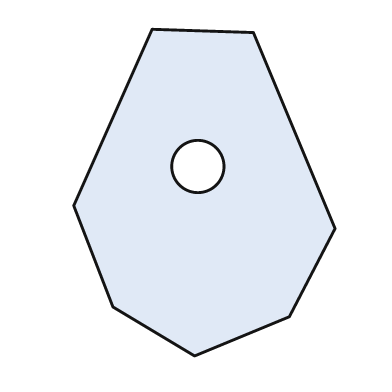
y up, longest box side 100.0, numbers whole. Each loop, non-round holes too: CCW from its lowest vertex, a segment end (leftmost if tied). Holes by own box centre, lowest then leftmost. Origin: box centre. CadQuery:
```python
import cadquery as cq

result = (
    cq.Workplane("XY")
    .moveTo(-3.0, -50.0)
    .lineTo(26.0, -38.0)
    .lineTo(40.0, -11.0)
    .lineTo(15.0, 49.0)
    .lineTo(-16.0, 50.0)
    .lineTo(-40.0, -4.0)
    .lineTo(-28.0, -35.0)
    .close()
    .moveTo(-2.0, 8.0)
    .circle(8.0)
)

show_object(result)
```